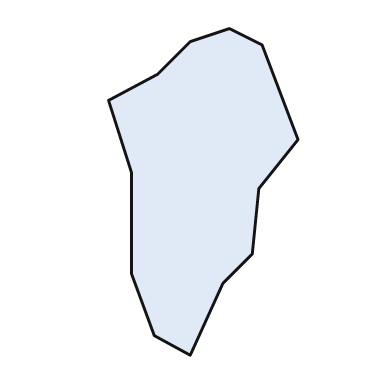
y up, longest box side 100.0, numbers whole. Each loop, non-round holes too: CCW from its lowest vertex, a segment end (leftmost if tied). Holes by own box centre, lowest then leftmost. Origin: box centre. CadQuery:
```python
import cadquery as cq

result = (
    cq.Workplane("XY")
    .moveTo(-4.0, -50.0)
    .lineTo(6.0, -28.0)
    .lineTo(15.0, -19.0)
    .lineTo(17.0, 1.0)
    .lineTo(29.0, 16.0)
    .lineTo(18.0, 45.0)
    .lineTo(8.0, 50.0)
    .lineTo(-4.0, 46.0)
    .lineTo(-14.0, 36.0)
    .lineTo(-29.0, 28.0)
    .lineTo(-22.0, 6.0)
    .lineTo(-22.0, -25.0)
    .lineTo(-15.0, -44.0)
    .close()
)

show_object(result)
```